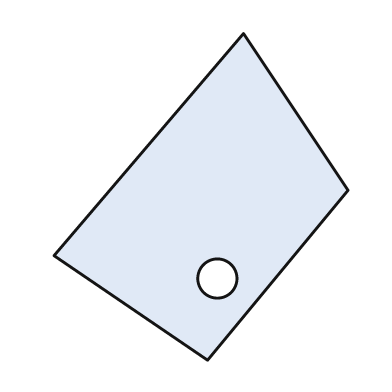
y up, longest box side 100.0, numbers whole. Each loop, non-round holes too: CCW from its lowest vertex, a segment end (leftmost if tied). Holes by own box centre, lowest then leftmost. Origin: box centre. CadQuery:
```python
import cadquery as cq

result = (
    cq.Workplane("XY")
    .moveTo(2.0, -50.0)
    .lineTo(45.0, 2.0)
    .lineTo(13.0, 50.0)
    .lineTo(-45.0, -18.0)
    .close()
    .moveTo(5.0, -25.0)
    .circle(6.0)
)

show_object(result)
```